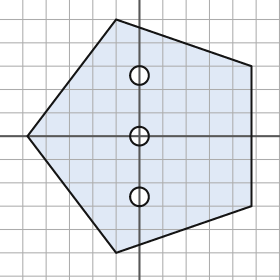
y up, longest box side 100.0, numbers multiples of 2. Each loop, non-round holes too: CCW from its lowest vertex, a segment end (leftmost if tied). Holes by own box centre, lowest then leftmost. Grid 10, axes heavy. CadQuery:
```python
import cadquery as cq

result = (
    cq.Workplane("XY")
    .moveTo(-10.0, -50.0)
    .lineTo(48.0, -30.0)
    .lineTo(48.0, 30.0)
    .lineTo(-10.0, 50.0)
    .lineTo(-48.0, 0.0)
    .close()
    .moveTo(0.0, -26.0)
    .circle(4.0)
    .moveTo(0.0, 0.0)
    .circle(4.0)
    .moveTo(0.0, 26.0)
    .circle(4.0)
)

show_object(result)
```